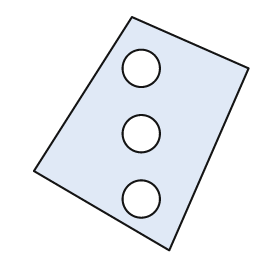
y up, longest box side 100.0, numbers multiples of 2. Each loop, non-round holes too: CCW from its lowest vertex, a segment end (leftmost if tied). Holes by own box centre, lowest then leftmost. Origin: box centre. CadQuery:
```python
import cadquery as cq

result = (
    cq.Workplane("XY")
    .moveTo(12.0, -50.0)
    .lineTo(46.0, 28.0)
    .lineTo(-4.0, 50.0)
    .lineTo(-46.0, -16.0)
    .close()
    .moveTo(0.0, -28.0)
    .circle(8.0)
    .moveTo(0.0, 0.0)
    .circle(8.0)
    .moveTo(0.0, 28.0)
    .circle(8.0)
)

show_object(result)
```